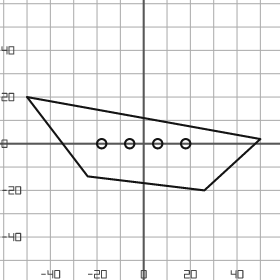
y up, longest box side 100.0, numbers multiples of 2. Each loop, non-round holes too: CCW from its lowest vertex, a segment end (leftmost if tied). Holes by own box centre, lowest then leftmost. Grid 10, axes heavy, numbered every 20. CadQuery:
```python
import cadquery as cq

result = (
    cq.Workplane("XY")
    .moveTo(26.0, -20.0)
    .lineTo(50.0, 2.0)
    .lineTo(-50.0, 20.0)
    .lineTo(-24.0, -14.0)
    .close()
    .moveTo(-18.0, 0.0)
    .circle(2.0)
    .moveTo(-6.0, 0.0)
    .circle(2.0)
    .moveTo(6.0, 0.0)
    .circle(2.0)
    .moveTo(18.0, 0.0)
    .circle(2.0)
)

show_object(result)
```